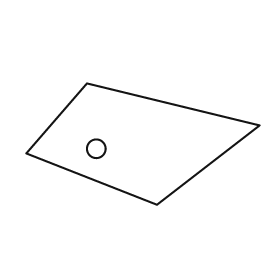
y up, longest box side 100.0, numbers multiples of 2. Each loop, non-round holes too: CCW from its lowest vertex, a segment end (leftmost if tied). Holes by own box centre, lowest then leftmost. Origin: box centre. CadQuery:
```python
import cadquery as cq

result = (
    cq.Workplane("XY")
    .moveTo(6.0, -26.0)
    .lineTo(50.0, 8.0)
    .lineTo(-24.0, 26.0)
    .lineTo(-50.0, -4.0)
    .close()
    .moveTo(-20.0, -2.0)
    .circle(4.0)
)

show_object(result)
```